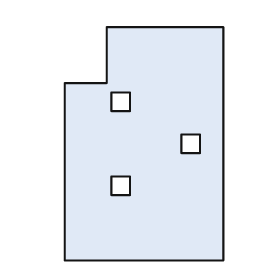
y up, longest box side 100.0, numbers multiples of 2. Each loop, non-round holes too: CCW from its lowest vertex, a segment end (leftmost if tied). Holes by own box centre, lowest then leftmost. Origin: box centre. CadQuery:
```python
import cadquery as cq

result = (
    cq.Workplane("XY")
    .moveTo(-34.0, -50.0)
    .lineTo(34.0, -50.0)
    .lineTo(34.0, 50.0)
    .lineTo(-16.0, 50.0)
    .lineTo(-16.0, 26.0)
    .lineTo(-34.0, 26.0)
    .close()
    .moveTo(-14.0, -22.0)
    .lineTo(-6.0, -22.0)
    .lineTo(-6.0, -14.0)
    .lineTo(-14.0, -14.0)
    .close()
    .moveTo(16.0, -4.0)
    .lineTo(24.0, -4.0)
    .lineTo(24.0, 4.0)
    .lineTo(16.0, 4.0)
    .close()
    .moveTo(-14.0, 14.0)
    .lineTo(-6.0, 14.0)
    .lineTo(-6.0, 22.0)
    .lineTo(-14.0, 22.0)
    .close()
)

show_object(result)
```